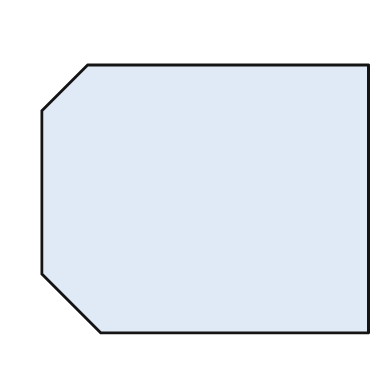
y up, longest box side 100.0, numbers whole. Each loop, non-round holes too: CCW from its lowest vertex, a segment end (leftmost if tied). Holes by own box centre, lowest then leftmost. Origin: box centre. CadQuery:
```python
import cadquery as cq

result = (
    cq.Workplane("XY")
    .moveTo(-32.0, -41.0)
    .lineTo(50.0, -41.0)
    .lineTo(50.0, 41.0)
    .lineTo(-36.0, 41.0)
    .lineTo(-50.0, 27.0)
    .lineTo(-50.0, -23.0)
    .close()
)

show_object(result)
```